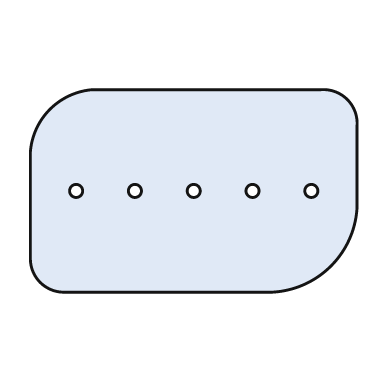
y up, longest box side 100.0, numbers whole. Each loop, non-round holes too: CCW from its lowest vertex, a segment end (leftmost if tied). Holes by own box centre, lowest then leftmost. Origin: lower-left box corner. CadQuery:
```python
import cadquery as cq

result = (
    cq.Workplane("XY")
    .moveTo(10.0, 0.0)
    .lineTo(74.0, 0.0)
    .threePointArc((92.0, 8.0), (100.0, 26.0))
    .lineTo(100.0, 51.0)
    .threePointArc((97.0, 59.0), (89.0, 62.0))
    .lineTo(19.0, 62.0)
    .threePointArc((6.0, 56.0), (0.0, 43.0))
    .lineTo(0.0, 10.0)
    .threePointArc((3.0, 3.0), (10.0, 0.0))
    .close()
    .moveTo(14.0, 31.0)
    .circle(2.0)
    .moveTo(32.0, 31.0)
    .circle(2.0)
    .moveTo(50.0, 31.0)
    .circle(2.0)
    .moveTo(68.0, 31.0)
    .circle(2.0)
    .moveTo(86.0, 31.0)
    .circle(2.0)
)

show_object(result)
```